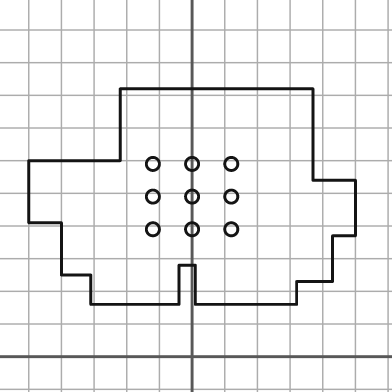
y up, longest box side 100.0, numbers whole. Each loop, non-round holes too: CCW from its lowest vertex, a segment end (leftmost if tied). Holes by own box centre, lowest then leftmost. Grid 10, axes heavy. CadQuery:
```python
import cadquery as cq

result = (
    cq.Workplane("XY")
    .moveTo(-31.0, 16.0)
    .lineTo(-4.0, 16.0)
    .lineTo(-4.0, 28.0)
    .lineTo(1.0, 28.0)
    .lineTo(1.0, 16.0)
    .lineTo(32.0, 16.0)
    .lineTo(32.0, 23.0)
    .lineTo(43.0, 23.0)
    .lineTo(43.0, 37.0)
    .lineTo(50.0, 37.0)
    .lineTo(50.0, 54.0)
    .lineTo(37.0, 54.0)
    .lineTo(37.0, 82.0)
    .lineTo(-22.0, 82.0)
    .lineTo(-22.0, 60.0)
    .lineTo(-50.0, 60.0)
    .lineTo(-50.0, 41.0)
    .lineTo(-40.0, 41.0)
    .lineTo(-40.0, 25.0)
    .lineTo(-31.0, 25.0)
    .close()
    .moveTo(-12.0, 39.0)
    .circle(2.0)
    .moveTo(0.0, 39.0)
    .circle(2.0)
    .moveTo(12.0, 39.0)
    .circle(2.0)
    .moveTo(-12.0, 49.0)
    .circle(2.0)
    .moveTo(0.0, 49.0)
    .circle(2.0)
    .moveTo(12.0, 49.0)
    .circle(2.0)
    .moveTo(-12.0, 59.0)
    .circle(2.0)
    .moveTo(0.0, 59.0)
    .circle(2.0)
    .moveTo(12.0, 59.0)
    .circle(2.0)
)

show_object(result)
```